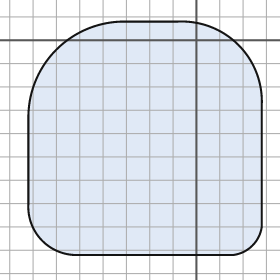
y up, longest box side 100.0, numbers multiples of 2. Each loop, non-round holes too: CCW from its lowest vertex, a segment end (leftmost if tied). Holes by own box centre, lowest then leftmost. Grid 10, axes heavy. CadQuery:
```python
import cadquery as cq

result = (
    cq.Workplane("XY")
    .moveTo(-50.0, -92.0)
    .lineTo(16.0, -92.0)
    .threePointArc((24.0, -88.0), (28.0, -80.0))
    .lineTo(28.0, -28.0)
    .threePointArc((18.0, -2.0), (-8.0, 8.0))
    .lineTo(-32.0, 8.0)
    .threePointArc((-60.0, -4.0), (-72.0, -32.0))
    .lineTo(-72.0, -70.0)
    .threePointArc((-66.0, -86.0), (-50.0, -92.0))
    .close()
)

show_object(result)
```